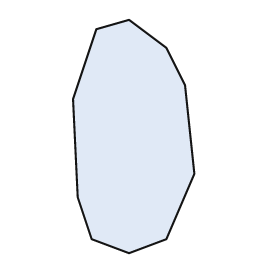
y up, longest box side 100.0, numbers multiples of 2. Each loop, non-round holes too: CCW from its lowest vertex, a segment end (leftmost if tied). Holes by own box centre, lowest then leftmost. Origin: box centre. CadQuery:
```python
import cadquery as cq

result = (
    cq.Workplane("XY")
    .moveTo(-2.0, -50.0)
    .lineTo(14.0, -44.0)
    .lineTo(26.0, -16.0)
    .lineTo(22.0, 22.0)
    .lineTo(14.0, 38.0)
    .lineTo(-2.0, 50.0)
    .lineTo(-16.0, 46.0)
    .lineTo(-26.0, 16.0)
    .lineTo(-24.0, -26.0)
    .lineTo(-18.0, -44.0)
    .close()
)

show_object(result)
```